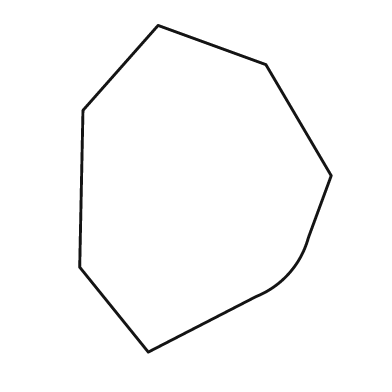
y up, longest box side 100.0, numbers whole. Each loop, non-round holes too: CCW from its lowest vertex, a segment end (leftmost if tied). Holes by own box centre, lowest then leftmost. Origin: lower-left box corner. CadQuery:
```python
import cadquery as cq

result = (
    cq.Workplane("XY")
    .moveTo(21.0, 0.0)
    .lineTo(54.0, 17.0)
    .threePointArc((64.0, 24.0), (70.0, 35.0))
    .lineTo(77.0, 54.0)
    .lineTo(57.0, 88.0)
    .lineTo(24.0, 100.0)
    .lineTo(1.0, 74.0)
    .lineTo(0.0, 26.0)
    .close()
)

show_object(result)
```